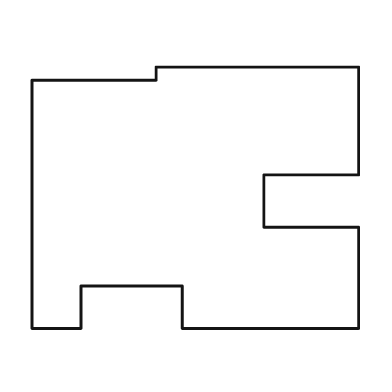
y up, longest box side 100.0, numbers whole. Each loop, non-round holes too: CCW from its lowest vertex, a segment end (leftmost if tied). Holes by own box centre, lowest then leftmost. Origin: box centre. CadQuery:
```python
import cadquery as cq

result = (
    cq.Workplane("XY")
    .moveTo(-50.0, -40.0)
    .lineTo(-35.0, -40.0)
    .lineTo(-35.0, -27.0)
    .lineTo(-4.0, -27.0)
    .lineTo(-4.0, -40.0)
    .lineTo(50.0, -40.0)
    .lineTo(50.0, -9.0)
    .lineTo(21.0, -9.0)
    .lineTo(21.0, 7.0)
    .lineTo(50.0, 7.0)
    .lineTo(50.0, 40.0)
    .lineTo(-12.0, 40.0)
    .lineTo(-12.0, 36.0)
    .lineTo(-50.0, 36.0)
    .close()
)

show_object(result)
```